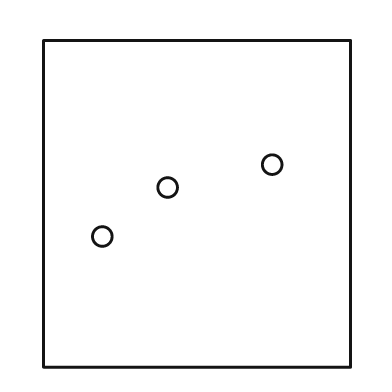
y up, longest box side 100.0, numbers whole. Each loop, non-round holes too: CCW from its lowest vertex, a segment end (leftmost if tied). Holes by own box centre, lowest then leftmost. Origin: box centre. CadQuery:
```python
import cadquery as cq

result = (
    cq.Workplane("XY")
    .moveTo(-47.0, -50.0)
    .lineTo(47.0, -50.0)
    .lineTo(47.0, 50.0)
    .lineTo(-47.0, 50.0)
    .close()
    .moveTo(-29.0, -10.0)
    .circle(3.0)
    .moveTo(-9.0, 5.0)
    .circle(3.0)
    .moveTo(23.0, 12.0)
    .circle(3.0)
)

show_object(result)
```